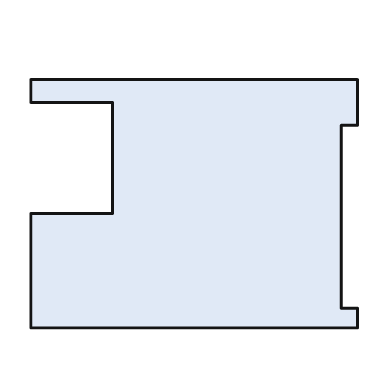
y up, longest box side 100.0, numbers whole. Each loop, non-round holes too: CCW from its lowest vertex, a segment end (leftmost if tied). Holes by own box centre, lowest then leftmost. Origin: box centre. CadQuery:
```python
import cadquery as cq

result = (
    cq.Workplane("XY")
    .moveTo(-50.0, -38.0)
    .lineTo(50.0, -38.0)
    .lineTo(50.0, -32.0)
    .lineTo(45.0, -32.0)
    .lineTo(45.0, 24.0)
    .lineTo(50.0, 24.0)
    .lineTo(50.0, 38.0)
    .lineTo(-50.0, 38.0)
    .lineTo(-50.0, 31.0)
    .lineTo(-25.0, 31.0)
    .lineTo(-25.0, -3.0)
    .lineTo(-50.0, -3.0)
    .close()
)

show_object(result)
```